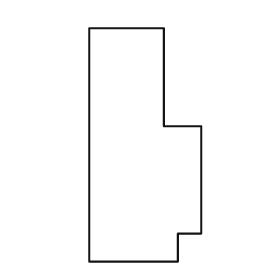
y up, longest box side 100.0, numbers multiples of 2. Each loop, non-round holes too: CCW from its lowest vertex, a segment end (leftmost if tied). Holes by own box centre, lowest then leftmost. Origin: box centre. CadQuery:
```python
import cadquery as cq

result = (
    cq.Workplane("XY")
    .moveTo(-24.0, -50.0)
    .lineTo(14.0, -50.0)
    .lineTo(14.0, -38.0)
    .lineTo(24.0, -38.0)
    .lineTo(24.0, 8.0)
    .lineTo(8.0, 8.0)
    .lineTo(8.0, 50.0)
    .lineTo(-24.0, 50.0)
    .close()
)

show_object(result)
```